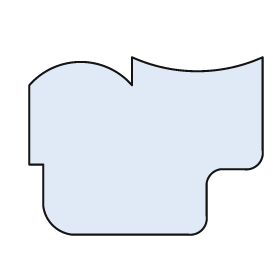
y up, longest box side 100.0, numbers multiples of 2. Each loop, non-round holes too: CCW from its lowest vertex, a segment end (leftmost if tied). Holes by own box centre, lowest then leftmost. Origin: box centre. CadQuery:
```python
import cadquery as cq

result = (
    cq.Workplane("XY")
    .moveTo(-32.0, -38.0)
    .lineTo(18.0, -38.0)
    .threePointArc((24.0, -36.0), (26.0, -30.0))
    .lineTo(26.0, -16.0)
    .threePointArc((28.0, -12.0), (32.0, -10.0))
    .lineTo(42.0, -10.0)
    .threePointArc((48.0, -8.0), (50.0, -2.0))
    .lineTo(50.0, 38.0)
    .threePointArc((22.0, 32.0), (-6.0, 38.0))
    .lineTo(-6.0, 26.0)
    .threePointArc((-28.0, 36.0), (-50.0, 26.0))
    .lineTo(-50.0, -8.0)
    .lineTo(-44.0, -8.0)
    .lineTo(-44.0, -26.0)
    .threePointArc((-40.0, -34.0), (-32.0, -38.0))
    .close()
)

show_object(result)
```